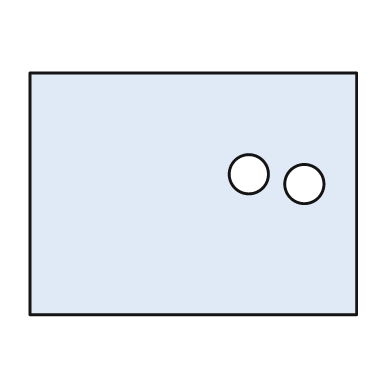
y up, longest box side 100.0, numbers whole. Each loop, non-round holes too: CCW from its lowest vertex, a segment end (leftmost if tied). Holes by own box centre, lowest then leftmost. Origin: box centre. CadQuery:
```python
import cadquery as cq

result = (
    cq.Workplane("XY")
    .moveTo(-50.0, -37.0)
    .lineTo(50.0, -37.0)
    .lineTo(50.0, 37.0)
    .lineTo(-50.0, 37.0)
    .close()
    .moveTo(34.0, 3.0)
    .circle(6.0)
    .moveTo(17.0, 6.0)
    .circle(6.0)
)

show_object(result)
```